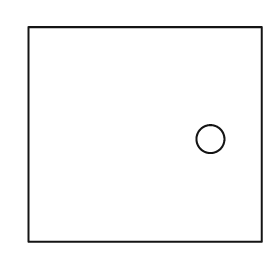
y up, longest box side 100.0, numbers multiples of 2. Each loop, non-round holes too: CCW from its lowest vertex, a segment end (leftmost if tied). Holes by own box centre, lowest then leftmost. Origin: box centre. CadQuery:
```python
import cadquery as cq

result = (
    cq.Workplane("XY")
    .moveTo(-50.0, -46.0)
    .lineTo(50.0, -46.0)
    .lineTo(50.0, 46.0)
    .lineTo(-50.0, 46.0)
    .close()
    .moveTo(28.0, -2.0)
    .circle(6.0)
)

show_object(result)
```